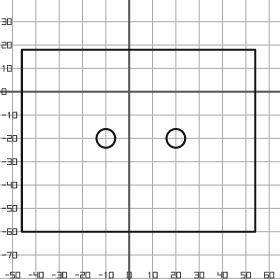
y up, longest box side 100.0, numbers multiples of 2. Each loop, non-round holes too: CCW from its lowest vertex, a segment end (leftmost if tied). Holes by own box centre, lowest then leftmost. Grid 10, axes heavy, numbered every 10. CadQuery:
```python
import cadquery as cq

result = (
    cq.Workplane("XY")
    .moveTo(-46.0, -60.0)
    .lineTo(54.0, -60.0)
    .lineTo(54.0, 18.0)
    .lineTo(-46.0, 18.0)
    .close()
    .moveTo(-10.0, -20.0)
    .circle(4.0)
    .moveTo(20.0, -20.0)
    .circle(4.0)
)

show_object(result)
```